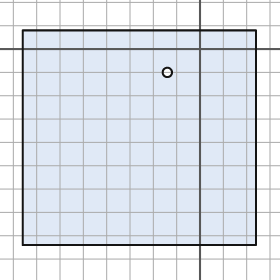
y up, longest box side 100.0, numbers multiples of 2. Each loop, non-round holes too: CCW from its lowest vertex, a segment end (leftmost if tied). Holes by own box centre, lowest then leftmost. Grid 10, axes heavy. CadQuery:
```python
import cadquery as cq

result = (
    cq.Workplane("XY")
    .moveTo(-76.0, -84.0)
    .lineTo(24.0, -84.0)
    .lineTo(24.0, 8.0)
    .lineTo(-76.0, 8.0)
    .close()
    .moveTo(-14.0, -10.0)
    .circle(2.0)
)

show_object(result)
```